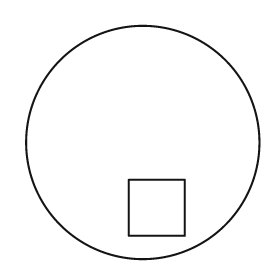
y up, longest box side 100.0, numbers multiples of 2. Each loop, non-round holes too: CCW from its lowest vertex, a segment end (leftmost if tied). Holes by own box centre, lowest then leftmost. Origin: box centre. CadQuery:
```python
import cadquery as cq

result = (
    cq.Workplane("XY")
    .moveTo(0.0, 0.0)
    .circle(50.0)
    .moveTo(-6.0, -40.0)
    .lineTo(18.0, -40.0)
    .lineTo(18.0, -16.0)
    .lineTo(-6.0, -16.0)
    .close()
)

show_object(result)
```